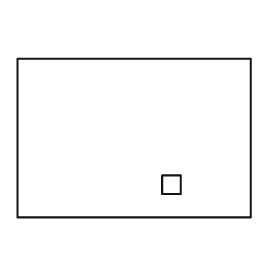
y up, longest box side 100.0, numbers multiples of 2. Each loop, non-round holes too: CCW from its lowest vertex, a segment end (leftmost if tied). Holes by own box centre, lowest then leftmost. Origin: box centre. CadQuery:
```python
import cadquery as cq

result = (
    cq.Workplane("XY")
    .moveTo(-50.0, -34.0)
    .lineTo(50.0, -34.0)
    .lineTo(50.0, 34.0)
    .lineTo(-50.0, 34.0)
    .close()
    .moveTo(12.0, -24.0)
    .lineTo(20.0, -24.0)
    .lineTo(20.0, -16.0)
    .lineTo(12.0, -16.0)
    .close()
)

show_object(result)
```